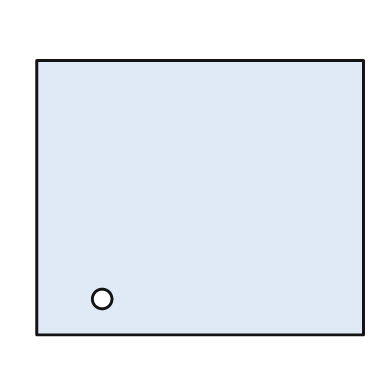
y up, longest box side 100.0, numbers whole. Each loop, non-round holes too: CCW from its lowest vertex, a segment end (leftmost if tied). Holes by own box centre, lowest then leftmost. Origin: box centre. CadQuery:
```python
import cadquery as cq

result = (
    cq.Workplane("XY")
    .moveTo(-50.0, -42.0)
    .lineTo(50.0, -42.0)
    .lineTo(50.0, 42.0)
    .lineTo(-50.0, 42.0)
    .close()
    .moveTo(-30.0, -31.0)
    .circle(3.0)
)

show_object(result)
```